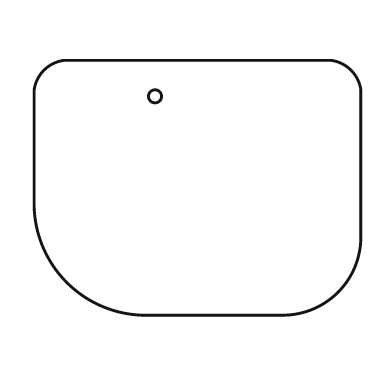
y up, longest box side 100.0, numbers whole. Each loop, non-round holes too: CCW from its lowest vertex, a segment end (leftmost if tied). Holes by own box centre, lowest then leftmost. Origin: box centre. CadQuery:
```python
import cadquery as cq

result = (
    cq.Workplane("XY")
    .moveTo(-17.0, -39.0)
    .lineTo(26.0, -39.0)
    .threePointArc((43.0, -32.0), (50.0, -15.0))
    .lineTo(50.0, 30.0)
    .threePointArc((47.0, 36.0), (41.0, 39.0))
    .lineTo(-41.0, 39.0)
    .threePointArc((-47.0, 36.0), (-50.0, 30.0))
    .lineTo(-50.0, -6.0)
    .threePointArc((-40.0, -29.0), (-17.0, -39.0))
    .close()
    .moveTo(-13.0, 28.0)
    .circle(2.0)
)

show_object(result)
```